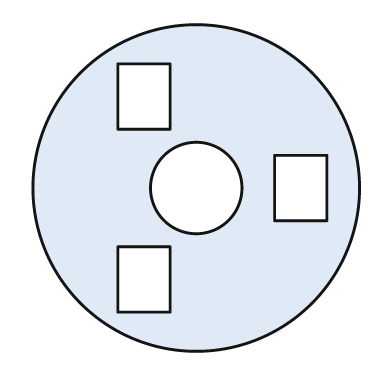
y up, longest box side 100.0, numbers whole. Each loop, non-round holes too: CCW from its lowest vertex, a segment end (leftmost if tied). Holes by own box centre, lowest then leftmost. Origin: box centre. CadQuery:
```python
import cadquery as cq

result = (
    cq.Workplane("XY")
    .moveTo(0.0, 0.0)
    .circle(50.0)
    .moveTo(-24.0, -38.0)
    .lineTo(-8.0, -38.0)
    .lineTo(-8.0, -18.0)
    .lineTo(-24.0, -18.0)
    .close()
    .moveTo(0.0, 0.0)
    .circle(14.0)
    .moveTo(24.0, -10.0)
    .lineTo(40.0, -10.0)
    .lineTo(40.0, 10.0)
    .lineTo(24.0, 10.0)
    .close()
    .moveTo(-24.0, 18.0)
    .lineTo(-8.0, 18.0)
    .lineTo(-8.0, 38.0)
    .lineTo(-24.0, 38.0)
    .close()
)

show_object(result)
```